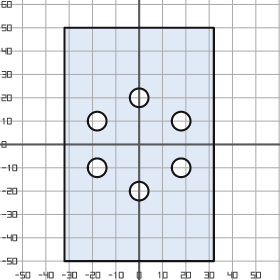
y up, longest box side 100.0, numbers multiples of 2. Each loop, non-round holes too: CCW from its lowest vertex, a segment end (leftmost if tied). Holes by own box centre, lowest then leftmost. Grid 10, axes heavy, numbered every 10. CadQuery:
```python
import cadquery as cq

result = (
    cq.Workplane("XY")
    .moveTo(-32.0, -50.0)
    .lineTo(32.0, -50.0)
    .lineTo(32.0, 50.0)
    .lineTo(-32.0, 50.0)
    .close()
    .moveTo(0.0, -20.0)
    .circle(4.0)
    .moveTo(-18.0, -10.0)
    .circle(4.0)
    .moveTo(18.0, -10.0)
    .circle(4.0)
    .moveTo(-18.0, 10.0)
    .circle(4.0)
    .moveTo(18.0, 10.0)
    .circle(4.0)
    .moveTo(0.0, 20.0)
    .circle(4.0)
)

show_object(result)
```